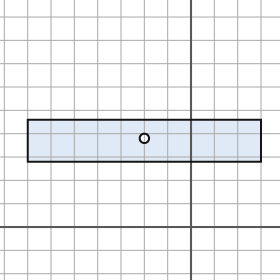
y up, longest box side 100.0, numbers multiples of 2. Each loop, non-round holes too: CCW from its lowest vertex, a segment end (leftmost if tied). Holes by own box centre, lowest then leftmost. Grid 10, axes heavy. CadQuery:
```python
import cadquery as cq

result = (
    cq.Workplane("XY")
    .moveTo(-70.0, 28.0)
    .lineTo(30.0, 28.0)
    .lineTo(30.0, 46.0)
    .lineTo(-70.0, 46.0)
    .close()
    .moveTo(-20.0, 38.0)
    .circle(2.0)
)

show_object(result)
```